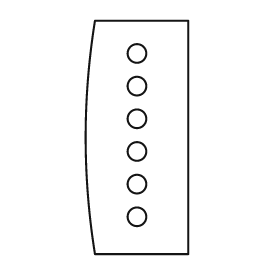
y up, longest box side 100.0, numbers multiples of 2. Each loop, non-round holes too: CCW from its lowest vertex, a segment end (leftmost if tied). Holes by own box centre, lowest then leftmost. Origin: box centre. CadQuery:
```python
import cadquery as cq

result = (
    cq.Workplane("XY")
    .moveTo(-18.0, -50.0)
    .lineTo(22.0, -50.0)
    .lineTo(22.0, 50.0)
    .lineTo(-18.0, 50.0)
    .threePointArc((-22.0, 0.0), (-18.0, -50.0))
    .close()
    .moveTo(0.0, -34.0)
    .circle(4.0)
    .moveTo(0.0, -20.0)
    .circle(4.0)
    .moveTo(0.0, -6.0)
    .circle(4.0)
    .moveTo(0.0, 8.0)
    .circle(4.0)
    .moveTo(0.0, 22.0)
    .circle(4.0)
    .moveTo(0.0, 36.0)
    .circle(4.0)
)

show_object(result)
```